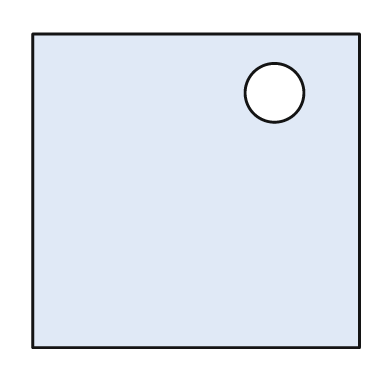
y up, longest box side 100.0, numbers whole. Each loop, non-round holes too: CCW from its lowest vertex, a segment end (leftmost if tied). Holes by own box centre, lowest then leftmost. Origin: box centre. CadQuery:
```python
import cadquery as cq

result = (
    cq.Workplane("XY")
    .moveTo(-50.0, -48.0)
    .lineTo(50.0, -48.0)
    .lineTo(50.0, 48.0)
    .lineTo(-50.0, 48.0)
    .close()
    .moveTo(24.0, 30.0)
    .circle(9.0)
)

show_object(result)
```